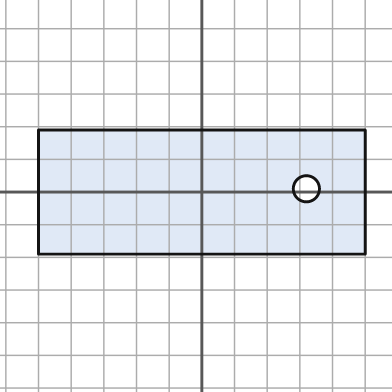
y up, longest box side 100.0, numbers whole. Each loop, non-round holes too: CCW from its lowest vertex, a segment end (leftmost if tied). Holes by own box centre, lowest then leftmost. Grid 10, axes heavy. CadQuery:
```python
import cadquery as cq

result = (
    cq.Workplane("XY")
    .moveTo(-50.0, -19.0)
    .lineTo(50.0, -19.0)
    .lineTo(50.0, 19.0)
    .lineTo(-50.0, 19.0)
    .close()
    .moveTo(32.0, 1.0)
    .circle(4.0)
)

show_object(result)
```